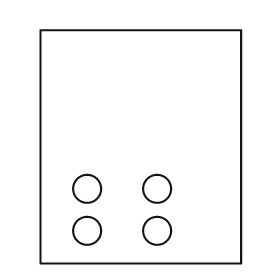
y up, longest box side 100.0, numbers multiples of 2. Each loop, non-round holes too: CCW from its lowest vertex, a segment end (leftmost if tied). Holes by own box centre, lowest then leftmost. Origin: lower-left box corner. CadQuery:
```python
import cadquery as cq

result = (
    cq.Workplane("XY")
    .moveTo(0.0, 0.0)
    .lineTo(86.0, 0.0)
    .lineTo(86.0, 100.0)
    .lineTo(0.0, 100.0)
    .close()
    .moveTo(20.0, 14.0)
    .circle(6.0)
    .moveTo(50.0, 14.0)
    .circle(6.0)
    .moveTo(20.0, 32.0)
    .circle(6.0)
    .moveTo(50.0, 32.0)
    .circle(6.0)
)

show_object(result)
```